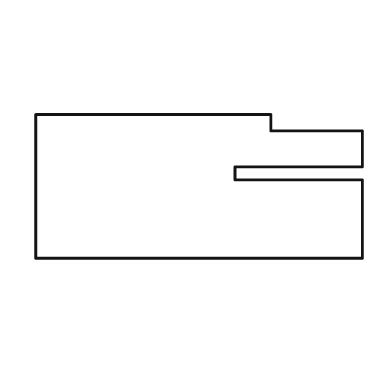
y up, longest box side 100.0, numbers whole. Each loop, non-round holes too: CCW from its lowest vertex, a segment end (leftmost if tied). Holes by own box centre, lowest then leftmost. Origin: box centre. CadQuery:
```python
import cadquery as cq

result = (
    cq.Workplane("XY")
    .moveTo(-50.0, -22.0)
    .lineTo(50.0, -22.0)
    .lineTo(50.0, 2.0)
    .lineTo(11.0, 2.0)
    .lineTo(11.0, 6.0)
    .lineTo(50.0, 6.0)
    .lineTo(50.0, 17.0)
    .lineTo(22.0, 17.0)
    .lineTo(22.0, 22.0)
    .lineTo(-50.0, 22.0)
    .close()
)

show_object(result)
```